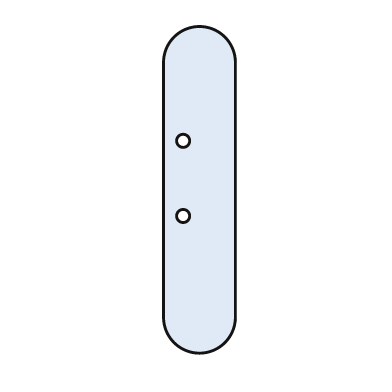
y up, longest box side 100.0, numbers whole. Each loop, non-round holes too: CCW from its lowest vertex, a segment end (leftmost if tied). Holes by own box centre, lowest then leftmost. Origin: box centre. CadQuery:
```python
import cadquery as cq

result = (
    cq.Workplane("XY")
    .moveTo(-11.0, -39.0)
    .threePointArc((0.0, -50.0), (11.0, -39.0))
    .lineTo(11.0, 39.0)
    .threePointArc((0.0, 50.0), (-11.0, 39.0))
    .close()
    .moveTo(-5.0, -8.0)
    .circle(2.0)
    .moveTo(-5.0, 15.0)
    .circle(2.0)
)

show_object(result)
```